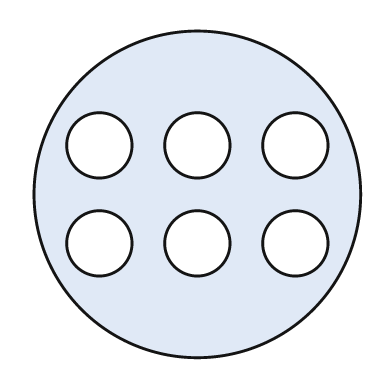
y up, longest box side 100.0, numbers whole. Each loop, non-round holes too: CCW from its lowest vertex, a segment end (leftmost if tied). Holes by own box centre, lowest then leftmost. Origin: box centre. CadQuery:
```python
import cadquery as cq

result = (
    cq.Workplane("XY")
    .moveTo(0.0, 0.0)
    .circle(50.0)
    .moveTo(-30.0, -15.0)
    .circle(10.0)
    .moveTo(0.0, -15.0)
    .circle(10.0)
    .moveTo(30.0, -15.0)
    .circle(10.0)
    .moveTo(-30.0, 15.0)
    .circle(10.0)
    .moveTo(0.0, 15.0)
    .circle(10.0)
    .moveTo(30.0, 15.0)
    .circle(10.0)
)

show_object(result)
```